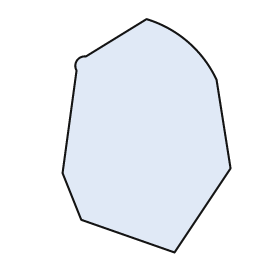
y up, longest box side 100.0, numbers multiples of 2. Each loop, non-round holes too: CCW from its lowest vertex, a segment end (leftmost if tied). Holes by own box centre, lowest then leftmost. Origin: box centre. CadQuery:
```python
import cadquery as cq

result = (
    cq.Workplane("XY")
    .moveTo(12.0, -50.0)
    .lineTo(36.0, -14.0)
    .lineTo(30.0, 24.0)
    .threePointArc((18.0, 40.0), (0.0, 50.0))
    .lineTo(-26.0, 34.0)
    .threePointArc((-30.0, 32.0), (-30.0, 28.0))
    .lineTo(-36.0, -16.0)
    .lineTo(-28.0, -36.0)
    .close()
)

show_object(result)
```